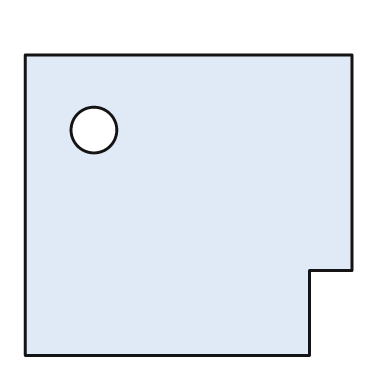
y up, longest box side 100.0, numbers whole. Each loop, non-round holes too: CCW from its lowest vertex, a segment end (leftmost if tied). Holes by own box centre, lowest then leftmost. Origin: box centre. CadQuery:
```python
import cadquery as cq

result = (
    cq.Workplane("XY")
    .moveTo(-50.0, -46.0)
    .lineTo(37.0, -46.0)
    .lineTo(37.0, -20.0)
    .lineTo(50.0, -20.0)
    .lineTo(50.0, 46.0)
    .lineTo(-50.0, 46.0)
    .close()
    .moveTo(-29.0, 23.0)
    .circle(7.0)
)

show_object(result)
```